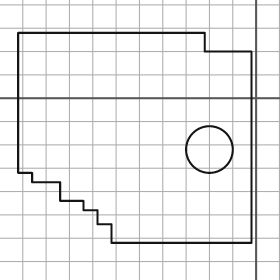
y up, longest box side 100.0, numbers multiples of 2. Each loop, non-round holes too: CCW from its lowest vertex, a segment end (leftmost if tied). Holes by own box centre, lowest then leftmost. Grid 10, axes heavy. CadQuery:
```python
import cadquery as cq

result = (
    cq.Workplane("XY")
    .moveTo(-62.0, -62.0)
    .lineTo(-2.0, -62.0)
    .lineTo(-2.0, 20.0)
    .lineTo(-22.0, 20.0)
    .lineTo(-22.0, 28.0)
    .lineTo(-102.0, 28.0)
    .lineTo(-102.0, -32.0)
    .lineTo(-96.0, -32.0)
    .lineTo(-96.0, -36.0)
    .lineTo(-84.0, -36.0)
    .lineTo(-84.0, -44.0)
    .lineTo(-74.0, -44.0)
    .lineTo(-74.0, -48.0)
    .lineTo(-68.0, -48.0)
    .lineTo(-68.0, -54.0)
    .lineTo(-62.0, -54.0)
    .close()
    .moveTo(-20.0, -22.0)
    .circle(10.0)
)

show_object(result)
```